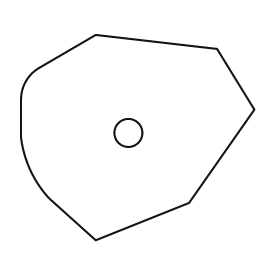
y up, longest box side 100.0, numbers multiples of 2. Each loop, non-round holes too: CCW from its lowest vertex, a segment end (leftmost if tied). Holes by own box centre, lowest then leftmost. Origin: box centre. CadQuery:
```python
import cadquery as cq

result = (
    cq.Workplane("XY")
    .moveTo(-18.0, -44.0)
    .lineTo(22.0, -28.0)
    .lineTo(50.0, 12.0)
    .lineTo(34.0, 38.0)
    .lineTo(-18.0, 44.0)
    .lineTo(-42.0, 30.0)
    .threePointArc((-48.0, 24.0), (-50.0, 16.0))
    .lineTo(-50.0, 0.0)
    .threePointArc((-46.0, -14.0), (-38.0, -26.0))
    .close()
    .moveTo(-4.0, 2.0)
    .circle(6.0)
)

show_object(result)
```